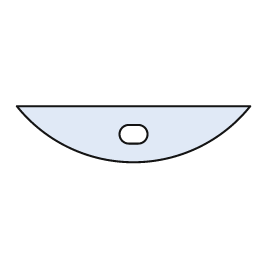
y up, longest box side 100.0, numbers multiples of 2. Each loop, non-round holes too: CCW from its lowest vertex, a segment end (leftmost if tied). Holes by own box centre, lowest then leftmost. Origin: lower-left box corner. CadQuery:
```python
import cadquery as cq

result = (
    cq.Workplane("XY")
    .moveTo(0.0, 24.0)
    .threePointArc((50.0, 0.0), (100.0, 24.0))
    .close()
    .moveTo(48.0, 8.0)
    .lineTo(52.0, 8.0)
    .threePointArc((56.0, 12.0), (52.0, 16.0))
    .lineTo(48.0, 16.0)
    .threePointArc((44.0, 12.0), (48.0, 8.0))
    .close()
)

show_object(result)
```